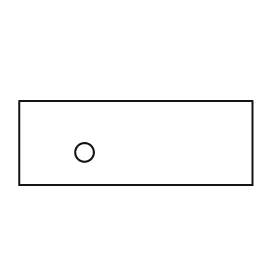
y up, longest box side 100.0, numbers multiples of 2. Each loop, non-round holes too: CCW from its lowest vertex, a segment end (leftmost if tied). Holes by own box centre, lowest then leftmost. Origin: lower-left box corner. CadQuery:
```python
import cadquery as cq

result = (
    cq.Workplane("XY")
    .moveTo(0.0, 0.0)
    .lineTo(100.0, 0.0)
    .lineTo(100.0, 36.0)
    .lineTo(0.0, 36.0)
    .close()
    .moveTo(28.0, 14.0)
    .circle(4.0)
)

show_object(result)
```